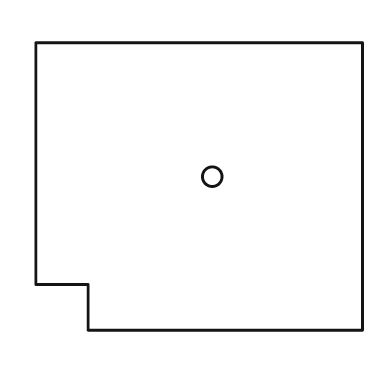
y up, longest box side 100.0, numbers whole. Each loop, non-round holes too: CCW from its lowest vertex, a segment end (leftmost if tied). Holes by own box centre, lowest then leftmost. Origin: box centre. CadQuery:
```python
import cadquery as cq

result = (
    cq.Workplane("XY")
    .moveTo(-34.0, -44.0)
    .lineTo(50.0, -44.0)
    .lineTo(50.0, 44.0)
    .lineTo(-50.0, 44.0)
    .lineTo(-50.0, -30.0)
    .lineTo(-34.0, -30.0)
    .close()
    .moveTo(4.0, 3.0)
    .circle(3.0)
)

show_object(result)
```